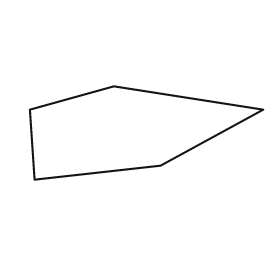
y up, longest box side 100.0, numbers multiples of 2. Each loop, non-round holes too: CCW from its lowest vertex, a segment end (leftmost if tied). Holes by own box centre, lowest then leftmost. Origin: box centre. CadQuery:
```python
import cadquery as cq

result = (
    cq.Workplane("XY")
    .moveTo(-48.0, -20.0)
    .lineTo(6.0, -14.0)
    .lineTo(50.0, 10.0)
    .lineTo(-14.0, 20.0)
    .lineTo(-50.0, 10.0)
    .close()
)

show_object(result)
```